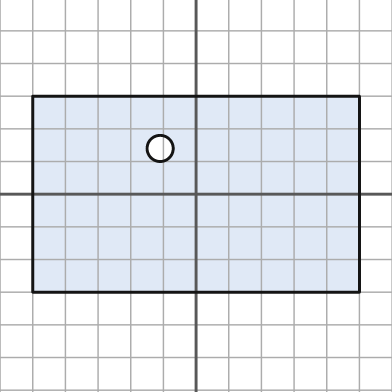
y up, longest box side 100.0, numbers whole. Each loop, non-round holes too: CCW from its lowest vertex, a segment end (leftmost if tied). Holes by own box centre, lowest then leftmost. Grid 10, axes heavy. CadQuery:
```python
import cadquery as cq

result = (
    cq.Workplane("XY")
    .moveTo(-50.0, -30.0)
    .lineTo(50.0, -30.0)
    .lineTo(50.0, 30.0)
    .lineTo(-50.0, 30.0)
    .close()
    .moveTo(-11.0, 14.0)
    .circle(4.0)
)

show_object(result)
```